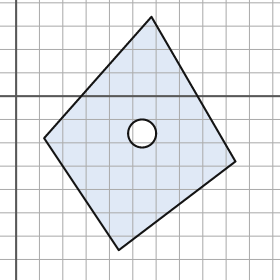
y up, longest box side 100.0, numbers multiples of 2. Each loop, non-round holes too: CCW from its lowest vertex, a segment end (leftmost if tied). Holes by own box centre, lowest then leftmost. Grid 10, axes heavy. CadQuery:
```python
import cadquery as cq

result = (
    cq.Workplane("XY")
    .moveTo(44.0, -66.0)
    .lineTo(94.0, -28.0)
    .lineTo(58.0, 34.0)
    .lineTo(12.0, -18.0)
    .close()
    .moveTo(54.0, -16.0)
    .circle(6.0)
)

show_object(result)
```